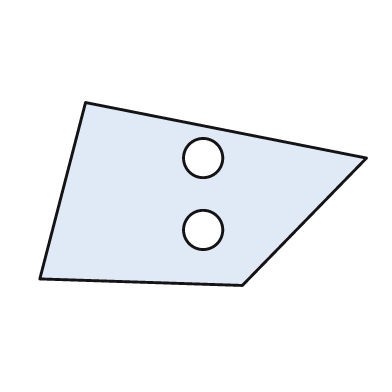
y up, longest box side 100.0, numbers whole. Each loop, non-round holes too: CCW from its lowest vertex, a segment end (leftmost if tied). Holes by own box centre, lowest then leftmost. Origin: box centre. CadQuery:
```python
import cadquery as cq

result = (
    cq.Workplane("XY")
    .moveTo(12.0, -28.0)
    .lineTo(50.0, 11.0)
    .lineTo(-36.0, 28.0)
    .lineTo(-50.0, -26.0)
    .close()
    .moveTo(0.0, -11.0)
    .circle(6.0)
    .moveTo(0.0, 11.0)
    .circle(6.0)
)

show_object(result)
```